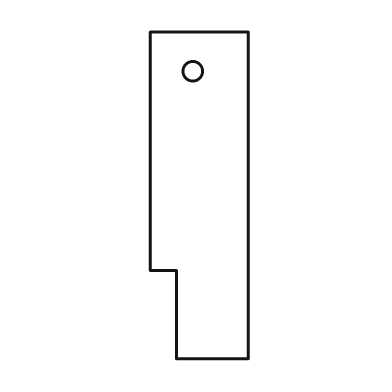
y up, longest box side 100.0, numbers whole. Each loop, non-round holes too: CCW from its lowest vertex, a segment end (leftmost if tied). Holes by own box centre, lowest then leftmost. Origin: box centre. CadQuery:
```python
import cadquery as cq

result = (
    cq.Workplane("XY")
    .moveTo(-7.0, -50.0)
    .lineTo(15.0, -50.0)
    .lineTo(15.0, 50.0)
    .lineTo(-15.0, 50.0)
    .lineTo(-15.0, -23.0)
    .lineTo(-7.0, -23.0)
    .close()
    .moveTo(-2.0, 38.0)
    .circle(3.0)
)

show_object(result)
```